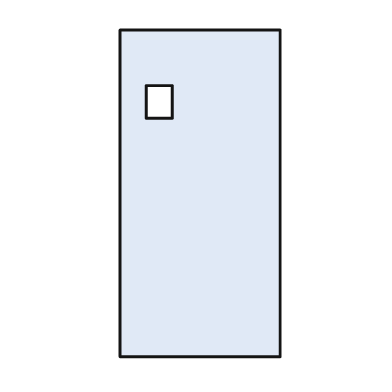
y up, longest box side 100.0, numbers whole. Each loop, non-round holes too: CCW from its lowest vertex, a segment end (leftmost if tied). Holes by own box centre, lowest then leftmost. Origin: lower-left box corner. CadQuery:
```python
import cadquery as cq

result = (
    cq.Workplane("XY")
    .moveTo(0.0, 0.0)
    .lineTo(49.0, 0.0)
    .lineTo(49.0, 100.0)
    .lineTo(0.0, 100.0)
    .close()
    .moveTo(8.0, 73.0)
    .lineTo(16.0, 73.0)
    .lineTo(16.0, 83.0)
    .lineTo(8.0, 83.0)
    .close()
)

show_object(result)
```